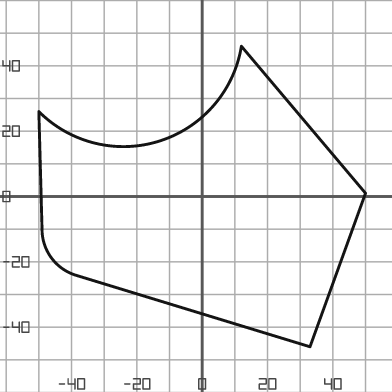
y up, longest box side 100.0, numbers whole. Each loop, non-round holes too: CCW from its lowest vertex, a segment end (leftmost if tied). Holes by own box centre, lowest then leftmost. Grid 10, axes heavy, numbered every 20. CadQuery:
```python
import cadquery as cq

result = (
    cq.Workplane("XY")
    .moveTo(33.0, -46.0)
    .lineTo(50.0, 1.0)
    .lineTo(12.0, 46.0)
    .threePointArc((-13.0, 17.0), (-50.0, 26.0))
    .lineTo(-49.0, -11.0)
    .threePointArc((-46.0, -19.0), (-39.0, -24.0))
    .close()
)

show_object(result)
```